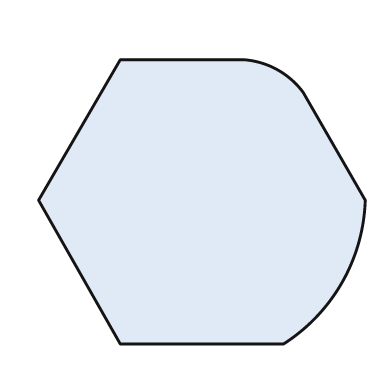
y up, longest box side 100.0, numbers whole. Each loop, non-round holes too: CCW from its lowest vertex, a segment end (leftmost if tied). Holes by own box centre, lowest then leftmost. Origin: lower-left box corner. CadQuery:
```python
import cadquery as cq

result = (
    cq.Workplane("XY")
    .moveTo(25.0, 0.0)
    .lineTo(75.0, 0.0)
    .threePointArc((93.0, 19.0), (100.0, 44.0))
    .lineTo(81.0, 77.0)
    .threePointArc((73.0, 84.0), (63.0, 87.0))
    .lineTo(25.0, 87.0)
    .lineTo(0.0, 44.0)
    .close()
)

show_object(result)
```